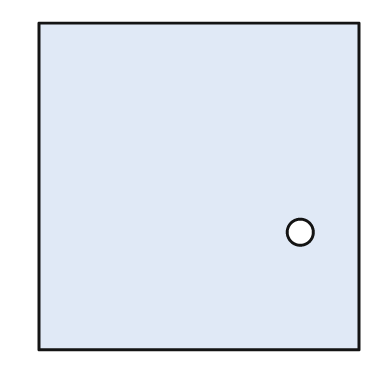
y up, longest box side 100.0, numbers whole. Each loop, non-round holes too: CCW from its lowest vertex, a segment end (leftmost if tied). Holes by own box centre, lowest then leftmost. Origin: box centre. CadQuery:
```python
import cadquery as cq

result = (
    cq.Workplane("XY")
    .moveTo(-49.0, -50.0)
    .lineTo(49.0, -50.0)
    .lineTo(49.0, 50.0)
    .lineTo(-49.0, 50.0)
    .close()
    .moveTo(31.0, -14.0)
    .circle(4.0)
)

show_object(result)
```